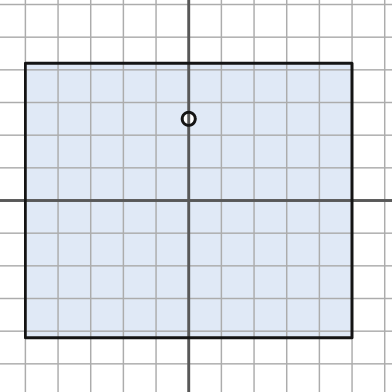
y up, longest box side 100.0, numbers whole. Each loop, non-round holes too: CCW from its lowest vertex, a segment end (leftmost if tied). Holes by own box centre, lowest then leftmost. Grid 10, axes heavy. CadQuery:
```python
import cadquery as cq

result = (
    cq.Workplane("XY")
    .moveTo(-50.0, -42.0)
    .lineTo(50.0, -42.0)
    .lineTo(50.0, 42.0)
    .lineTo(-50.0, 42.0)
    .close()
    .moveTo(0.0, 25.0)
    .circle(2.0)
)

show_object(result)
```